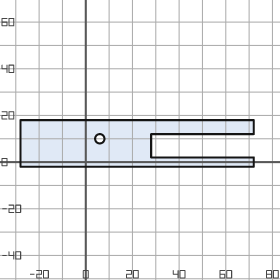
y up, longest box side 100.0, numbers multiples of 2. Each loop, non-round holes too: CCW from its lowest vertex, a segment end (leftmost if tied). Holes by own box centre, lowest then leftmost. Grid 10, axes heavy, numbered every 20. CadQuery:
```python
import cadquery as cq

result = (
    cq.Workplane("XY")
    .moveTo(-28.0, -2.0)
    .lineTo(72.0, -2.0)
    .lineTo(72.0, 2.0)
    .lineTo(28.0, 2.0)
    .lineTo(28.0, 12.0)
    .lineTo(72.0, 12.0)
    .lineTo(72.0, 18.0)
    .lineTo(-28.0, 18.0)
    .close()
    .moveTo(6.0, 10.0)
    .circle(2.0)
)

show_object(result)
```